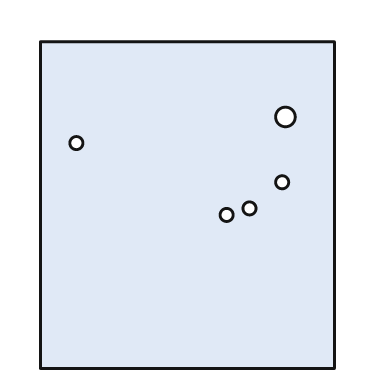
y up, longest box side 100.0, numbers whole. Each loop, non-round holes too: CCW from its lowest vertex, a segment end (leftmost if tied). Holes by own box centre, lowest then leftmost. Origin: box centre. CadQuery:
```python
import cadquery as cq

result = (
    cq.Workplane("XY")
    .moveTo(-45.0, -50.0)
    .lineTo(45.0, -50.0)
    .lineTo(45.0, 50.0)
    .lineTo(-45.0, 50.0)
    .close()
    .moveTo(12.0, -3.0)
    .circle(2.0)
    .moveTo(19.0, -1.0)
    .circle(2.0)
    .moveTo(29.0, 7.0)
    .circle(2.0)
    .moveTo(-34.0, 19.0)
    .circle(2.0)
    .moveTo(30.0, 27.0)
    .circle(3.0)
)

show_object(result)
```